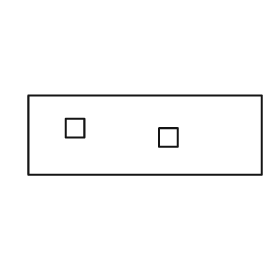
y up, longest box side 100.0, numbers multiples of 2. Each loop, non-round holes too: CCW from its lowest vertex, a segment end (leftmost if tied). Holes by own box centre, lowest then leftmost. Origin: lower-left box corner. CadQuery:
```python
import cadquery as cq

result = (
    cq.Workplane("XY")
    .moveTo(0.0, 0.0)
    .lineTo(100.0, 0.0)
    .lineTo(100.0, 34.0)
    .lineTo(0.0, 34.0)
    .close()
    .moveTo(56.0, 12.0)
    .lineTo(64.0, 12.0)
    .lineTo(64.0, 20.0)
    .lineTo(56.0, 20.0)
    .close()
    .moveTo(16.0, 16.0)
    .lineTo(24.0, 16.0)
    .lineTo(24.0, 24.0)
    .lineTo(16.0, 24.0)
    .close()
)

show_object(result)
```